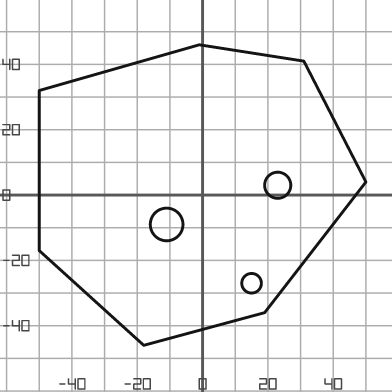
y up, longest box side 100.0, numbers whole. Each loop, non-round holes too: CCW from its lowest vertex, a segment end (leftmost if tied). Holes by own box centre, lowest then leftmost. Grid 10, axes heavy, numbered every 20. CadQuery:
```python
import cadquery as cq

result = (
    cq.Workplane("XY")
    .moveTo(-18.0, -46.0)
    .lineTo(19.0, -36.0)
    .lineTo(50.0, 4.0)
    .lineTo(31.0, 41.0)
    .lineTo(-1.0, 46.0)
    .lineTo(-50.0, 32.0)
    .lineTo(-50.0, -17.0)
    .close()
    .moveTo(15.0, -27.0)
    .circle(3.0)
    .moveTo(-11.0, -9.0)
    .circle(5.0)
    .moveTo(23.0, 3.0)
    .circle(4.0)
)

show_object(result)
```